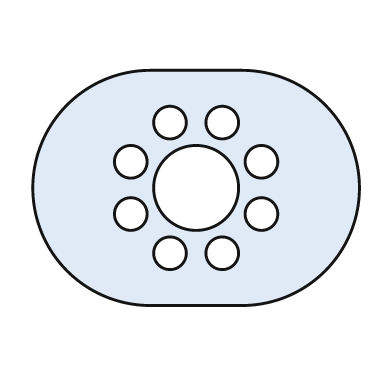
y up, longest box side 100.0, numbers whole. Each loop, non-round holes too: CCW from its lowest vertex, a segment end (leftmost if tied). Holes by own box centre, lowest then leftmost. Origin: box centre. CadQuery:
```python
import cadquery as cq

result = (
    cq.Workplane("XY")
    .moveTo(-14.0, -36.0)
    .lineTo(14.0, -36.0)
    .threePointArc((50.0, 0.0), (14.0, 36.0))
    .lineTo(-14.0, 36.0)
    .threePointArc((-50.0, 0.0), (-14.0, -36.0))
    .close()
    .moveTo(-8.0, -20.0)
    .circle(5.0)
    .moveTo(8.0, -20.0)
    .circle(5.0)
    .moveTo(-20.0, -8.0)
    .circle(5.0)
    .moveTo(20.0, -8.0)
    .circle(5.0)
    .moveTo(0.0, 0.0)
    .circle(13.0)
    .moveTo(-20.0, 8.0)
    .circle(5.0)
    .moveTo(20.0, 8.0)
    .circle(5.0)
    .moveTo(-8.0, 20.0)
    .circle(5.0)
    .moveTo(8.0, 20.0)
    .circle(5.0)
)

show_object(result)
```